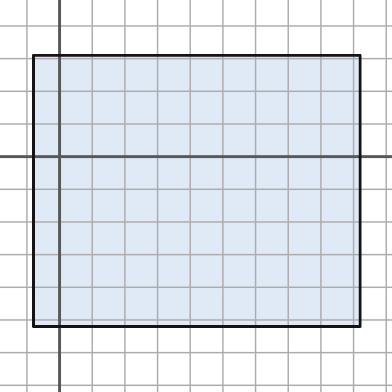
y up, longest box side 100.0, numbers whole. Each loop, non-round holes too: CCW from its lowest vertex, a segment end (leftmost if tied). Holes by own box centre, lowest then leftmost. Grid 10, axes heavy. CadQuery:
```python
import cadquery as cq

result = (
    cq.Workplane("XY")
    .moveTo(-8.0, -52.0)
    .lineTo(92.0, -52.0)
    .lineTo(92.0, 31.0)
    .lineTo(-8.0, 31.0)
    .close()
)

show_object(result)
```